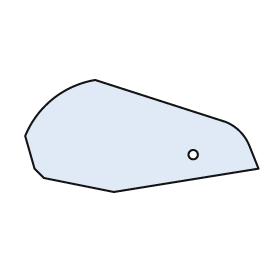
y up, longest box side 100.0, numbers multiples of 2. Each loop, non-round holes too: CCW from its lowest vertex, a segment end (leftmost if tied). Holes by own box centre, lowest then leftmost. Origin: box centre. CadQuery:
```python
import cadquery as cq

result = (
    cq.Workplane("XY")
    .moveTo(-12.0, -24.0)
    .lineTo(50.0, -14.0)
    .lineTo(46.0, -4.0)
    .threePointArc((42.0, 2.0), (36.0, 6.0))
    .lineTo(-20.0, 24.0)
    .threePointArc((-38.0, 16.0), (-50.0, 0.0))
    .lineTo(-46.0, -14.0)
    .lineTo(-42.0, -18.0)
    .close()
    .moveTo(22.0, -8.0)
    .circle(2.0)
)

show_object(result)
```